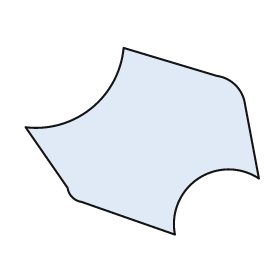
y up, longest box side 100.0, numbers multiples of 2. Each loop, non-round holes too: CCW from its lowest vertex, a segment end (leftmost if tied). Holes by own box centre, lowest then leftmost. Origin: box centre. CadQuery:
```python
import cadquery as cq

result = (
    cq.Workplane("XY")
    .moveTo(14.0, -40.0)
    .threePointArc((24.0, -16.0), (50.0, -16.0))
    .lineTo(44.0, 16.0)
    .threePointArc((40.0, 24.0), (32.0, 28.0))
    .lineTo(-8.0, 40.0)
    .threePointArc((-22.0, 14.0), (-50.0, 6.0))
    .lineTo(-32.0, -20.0)
    .threePointArc((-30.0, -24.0), (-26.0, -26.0))
    .close()
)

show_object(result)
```